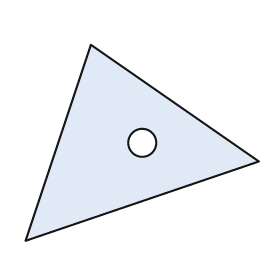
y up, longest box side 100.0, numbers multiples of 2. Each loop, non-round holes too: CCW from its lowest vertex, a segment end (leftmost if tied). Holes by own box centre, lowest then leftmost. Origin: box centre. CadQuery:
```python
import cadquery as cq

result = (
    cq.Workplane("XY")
    .moveTo(-50.0, -42.0)
    .lineTo(50.0, -8.0)
    .lineTo(-22.0, 42.0)
    .close()
    .moveTo(0.0, 0.0)
    .circle(6.0)
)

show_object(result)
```